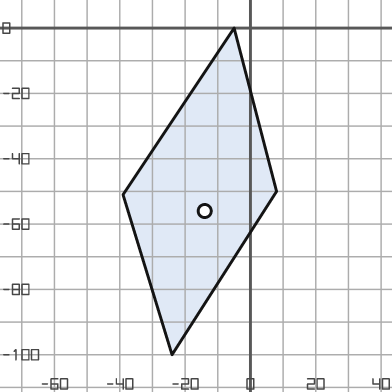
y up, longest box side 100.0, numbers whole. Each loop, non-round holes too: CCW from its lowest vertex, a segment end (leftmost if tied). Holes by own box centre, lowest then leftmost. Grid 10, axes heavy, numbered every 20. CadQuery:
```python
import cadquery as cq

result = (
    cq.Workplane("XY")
    .moveTo(-24.0, -100.0)
    .lineTo(8.0, -50.0)
    .lineTo(-5.0, 0.0)
    .lineTo(-39.0, -51.0)
    .close()
    .moveTo(-14.0, -56.0)
    .circle(2.0)
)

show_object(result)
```